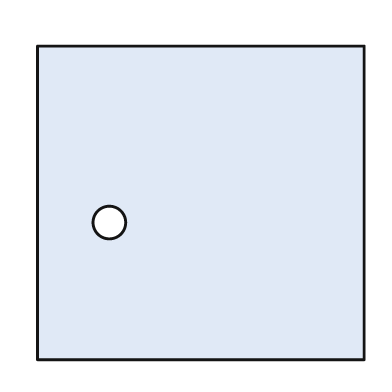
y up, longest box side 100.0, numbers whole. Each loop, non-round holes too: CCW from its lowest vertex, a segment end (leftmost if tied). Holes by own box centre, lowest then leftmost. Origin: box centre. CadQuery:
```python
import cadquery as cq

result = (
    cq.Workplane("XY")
    .moveTo(-50.0, -48.0)
    .lineTo(50.0, -48.0)
    .lineTo(50.0, 48.0)
    .lineTo(-50.0, 48.0)
    .close()
    .moveTo(-28.0, -6.0)
    .circle(5.0)
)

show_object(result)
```